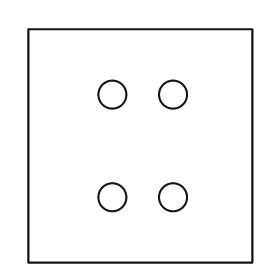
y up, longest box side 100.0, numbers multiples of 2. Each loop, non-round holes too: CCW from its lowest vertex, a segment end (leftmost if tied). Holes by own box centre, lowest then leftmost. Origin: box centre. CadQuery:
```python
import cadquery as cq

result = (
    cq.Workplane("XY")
    .moveTo(-48.0, -50.0)
    .lineTo(48.0, -50.0)
    .lineTo(48.0, 50.0)
    .lineTo(-48.0, 50.0)
    .close()
    .moveTo(-12.0, -22.0)
    .circle(6.0)
    .moveTo(14.0, -22.0)
    .circle(6.0)
    .moveTo(-12.0, 22.0)
    .circle(6.0)
    .moveTo(14.0, 22.0)
    .circle(6.0)
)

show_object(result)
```